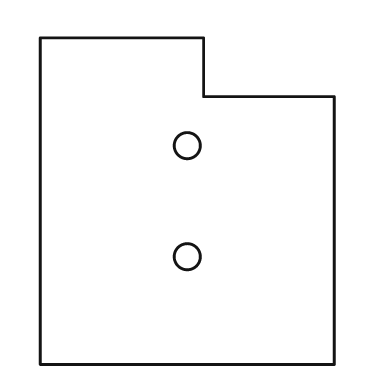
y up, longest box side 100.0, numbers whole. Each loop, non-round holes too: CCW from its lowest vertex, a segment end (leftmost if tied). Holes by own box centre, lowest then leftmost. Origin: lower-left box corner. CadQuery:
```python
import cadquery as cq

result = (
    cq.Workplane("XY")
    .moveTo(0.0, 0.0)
    .lineTo(90.0, 0.0)
    .lineTo(90.0, 82.0)
    .lineTo(50.0, 82.0)
    .lineTo(50.0, 100.0)
    .lineTo(0.0, 100.0)
    .close()
    .moveTo(45.0, 33.0)
    .circle(4.0)
    .moveTo(45.0, 67.0)
    .circle(4.0)
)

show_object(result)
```